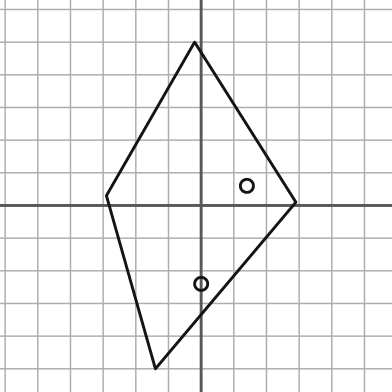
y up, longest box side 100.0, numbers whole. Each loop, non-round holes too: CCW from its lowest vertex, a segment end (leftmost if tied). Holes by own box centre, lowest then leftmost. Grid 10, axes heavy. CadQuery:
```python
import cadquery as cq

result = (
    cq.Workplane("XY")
    .moveTo(-14.0, -50.0)
    .lineTo(29.0, 1.0)
    .lineTo(-2.0, 50.0)
    .lineTo(-29.0, 3.0)
    .close()
    .moveTo(0.0, -24.0)
    .circle(2.0)
    .moveTo(14.0, 6.0)
    .circle(2.0)
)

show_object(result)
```